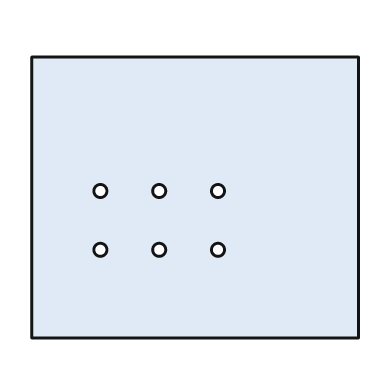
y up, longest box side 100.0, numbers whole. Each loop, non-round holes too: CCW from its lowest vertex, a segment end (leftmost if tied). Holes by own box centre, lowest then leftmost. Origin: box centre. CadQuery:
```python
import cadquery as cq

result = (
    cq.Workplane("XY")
    .moveTo(-50.0, -43.0)
    .lineTo(50.0, -43.0)
    .lineTo(50.0, 43.0)
    .lineTo(-50.0, 43.0)
    .close()
    .moveTo(-29.0, -16.0)
    .circle(2.0)
    .moveTo(-11.0, -16.0)
    .circle(2.0)
    .moveTo(7.0, -16.0)
    .circle(2.0)
    .moveTo(-29.0, 2.0)
    .circle(2.0)
    .moveTo(-11.0, 2.0)
    .circle(2.0)
    .moveTo(7.0, 2.0)
    .circle(2.0)
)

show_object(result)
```